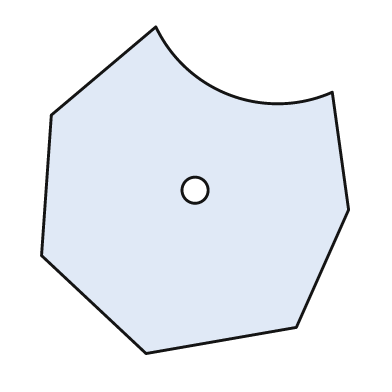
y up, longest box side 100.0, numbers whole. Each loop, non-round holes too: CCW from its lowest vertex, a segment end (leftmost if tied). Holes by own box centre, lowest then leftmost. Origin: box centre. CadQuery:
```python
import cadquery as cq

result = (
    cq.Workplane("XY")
    .moveTo(-15.0, -50.0)
    .lineTo(31.0, -42.0)
    .lineTo(47.0, -6.0)
    .lineTo(42.0, 30.0)
    .threePointArc((11.0, 29.0), (-12.0, 50.0))
    .lineTo(-44.0, 23.0)
    .lineTo(-47.0, -20.0)
    .close()
    .moveTo(0.0, 0.0)
    .circle(4.0)
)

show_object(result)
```